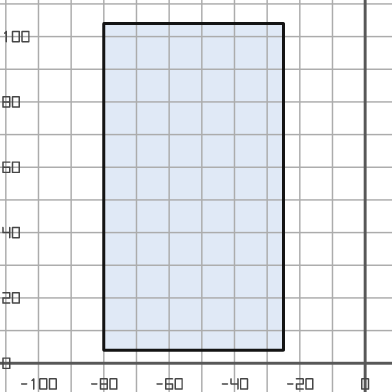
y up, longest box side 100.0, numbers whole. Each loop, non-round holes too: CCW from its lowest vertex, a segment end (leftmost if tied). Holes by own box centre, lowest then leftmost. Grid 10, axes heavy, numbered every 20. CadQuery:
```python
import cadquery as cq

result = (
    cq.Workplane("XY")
    .moveTo(-80.0, 4.0)
    .lineTo(-25.0, 4.0)
    .lineTo(-25.0, 104.0)
    .lineTo(-80.0, 104.0)
    .close()
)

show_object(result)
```